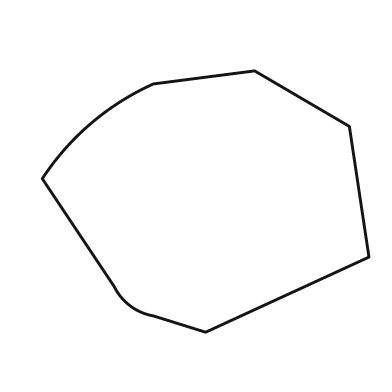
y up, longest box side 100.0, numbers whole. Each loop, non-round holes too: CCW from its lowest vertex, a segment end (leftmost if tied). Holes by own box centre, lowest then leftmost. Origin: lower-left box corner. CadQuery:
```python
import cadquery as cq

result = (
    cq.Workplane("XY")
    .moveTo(50.0, 0.0)
    .lineTo(100.0, 23.0)
    .lineTo(94.0, 63.0)
    .lineTo(65.0, 80.0)
    .lineTo(34.0, 76.0)
    .threePointArc((15.0, 64.0), (0.0, 47.0))
    .lineTo(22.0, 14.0)
    .threePointArc((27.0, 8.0), (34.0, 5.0))
    .close()
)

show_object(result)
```